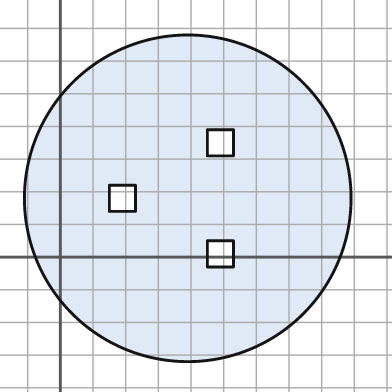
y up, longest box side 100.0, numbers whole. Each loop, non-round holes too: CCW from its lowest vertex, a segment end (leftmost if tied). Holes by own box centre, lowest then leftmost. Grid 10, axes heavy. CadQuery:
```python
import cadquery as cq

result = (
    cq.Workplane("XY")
    .moveTo(39.0, 18.0)
    .circle(50.0)
    .moveTo(45.0, -3.0)
    .lineTo(53.0, -3.0)
    .lineTo(53.0, 5.0)
    .lineTo(45.0, 5.0)
    .close()
    .moveTo(15.0, 14.0)
    .lineTo(23.0, 14.0)
    .lineTo(23.0, 22.0)
    .lineTo(15.0, 22.0)
    .close()
    .moveTo(45.0, 31.0)
    .lineTo(53.0, 31.0)
    .lineTo(53.0, 39.0)
    .lineTo(45.0, 39.0)
    .close()
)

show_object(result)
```